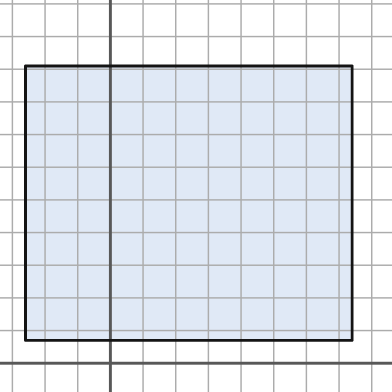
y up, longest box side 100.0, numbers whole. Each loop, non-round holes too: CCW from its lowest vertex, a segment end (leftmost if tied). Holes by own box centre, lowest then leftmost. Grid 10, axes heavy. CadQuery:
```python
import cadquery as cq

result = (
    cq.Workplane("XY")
    .moveTo(-26.0, 7.0)
    .lineTo(74.0, 7.0)
    .lineTo(74.0, 91.0)
    .lineTo(-26.0, 91.0)
    .close()
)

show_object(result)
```